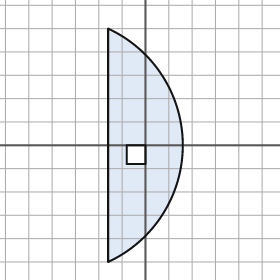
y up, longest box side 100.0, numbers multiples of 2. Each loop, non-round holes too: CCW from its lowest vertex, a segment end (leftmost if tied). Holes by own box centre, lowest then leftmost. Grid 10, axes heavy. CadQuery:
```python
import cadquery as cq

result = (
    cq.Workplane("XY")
    .moveTo(-16.0, -50.0)
    .threePointArc((16.0, 0.0), (-16.0, 50.0))
    .close()
    .moveTo(-8.0, -8.0)
    .lineTo(0.0, -8.0)
    .lineTo(0.0, 0.0)
    .lineTo(-8.0, 0.0)
    .close()
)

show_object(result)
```